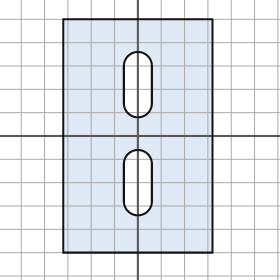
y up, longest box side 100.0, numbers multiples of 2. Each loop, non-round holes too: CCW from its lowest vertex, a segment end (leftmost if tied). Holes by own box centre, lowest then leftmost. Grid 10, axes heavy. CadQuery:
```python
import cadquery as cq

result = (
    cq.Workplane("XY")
    .moveTo(-32.0, -50.0)
    .lineTo(32.0, -50.0)
    .lineTo(32.0, 50.0)
    .lineTo(-32.0, 50.0)
    .close()
    .moveTo(-6.0, -28.0)
    .threePointArc((0.0, -34.0), (6.0, -28.0))
    .lineTo(6.0, -12.0)
    .threePointArc((0.0, -6.0), (-6.0, -12.0))
    .close()
    .moveTo(-6.0, 14.0)
    .threePointArc((0.0, 8.0), (6.0, 14.0))
    .lineTo(6.0, 30.0)
    .threePointArc((0.0, 36.0), (-6.0, 30.0))
    .close()
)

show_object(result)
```